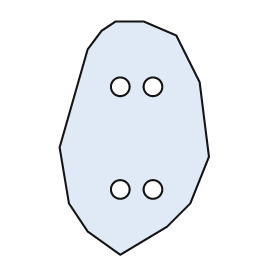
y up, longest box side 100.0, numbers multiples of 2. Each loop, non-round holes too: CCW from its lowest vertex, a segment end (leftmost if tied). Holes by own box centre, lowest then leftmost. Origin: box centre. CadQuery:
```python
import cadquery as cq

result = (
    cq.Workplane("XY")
    .moveTo(-6.0, -50.0)
    .lineTo(14.0, -38.0)
    .lineTo(24.0, -28.0)
    .lineTo(32.0, -8.0)
    .lineTo(28.0, 24.0)
    .lineTo(18.0, 44.0)
    .lineTo(4.0, 50.0)
    .lineTo(-8.0, 50.0)
    .lineTo(-14.0, 46.0)
    .lineTo(-20.0, 38.0)
    .lineTo(-32.0, -4.0)
    .lineTo(-28.0, -28.0)
    .lineTo(-20.0, -40.0)
    .close()
    .moveTo(-6.0, -22.0)
    .circle(4.0)
    .moveTo(8.0, -22.0)
    .circle(4.0)
    .moveTo(-6.0, 22.0)
    .circle(4.0)
    .moveTo(8.0, 22.0)
    .circle(4.0)
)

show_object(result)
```